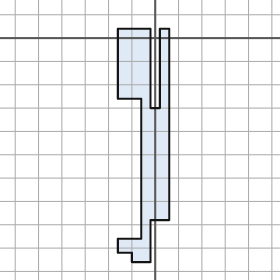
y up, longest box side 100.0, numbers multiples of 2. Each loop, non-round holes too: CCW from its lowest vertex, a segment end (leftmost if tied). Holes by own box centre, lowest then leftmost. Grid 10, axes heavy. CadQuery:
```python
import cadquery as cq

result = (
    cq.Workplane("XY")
    .moveTo(-10.0, -96.0)
    .lineTo(-2.0, -96.0)
    .lineTo(-2.0, -78.0)
    .lineTo(6.0, -78.0)
    .lineTo(6.0, 4.0)
    .lineTo(2.0, 4.0)
    .lineTo(2.0, -30.0)
    .lineTo(-2.0, -30.0)
    .lineTo(-2.0, 4.0)
    .lineTo(-16.0, 4.0)
    .lineTo(-16.0, -26.0)
    .lineTo(-6.0, -26.0)
    .lineTo(-6.0, -86.0)
    .lineTo(-16.0, -86.0)
    .lineTo(-16.0, -92.0)
    .lineTo(-10.0, -92.0)
    .close()
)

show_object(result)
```